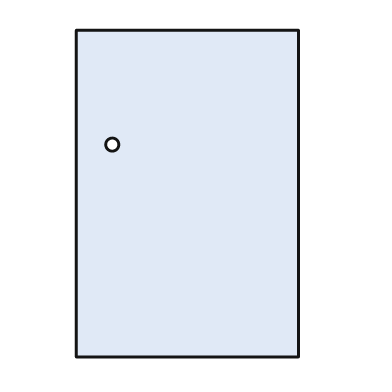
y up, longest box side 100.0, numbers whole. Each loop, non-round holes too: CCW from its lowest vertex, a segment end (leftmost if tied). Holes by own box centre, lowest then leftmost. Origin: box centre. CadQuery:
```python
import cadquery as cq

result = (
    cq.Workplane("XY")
    .moveTo(-34.0, -50.0)
    .lineTo(34.0, -50.0)
    .lineTo(34.0, 50.0)
    .lineTo(-34.0, 50.0)
    .close()
    .moveTo(-23.0, 15.0)
    .circle(2.0)
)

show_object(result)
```